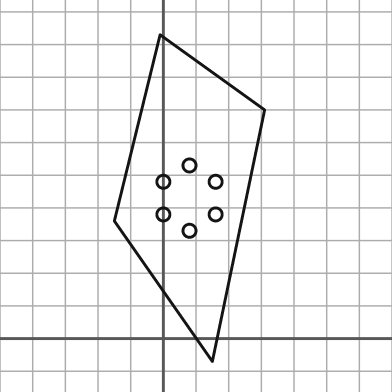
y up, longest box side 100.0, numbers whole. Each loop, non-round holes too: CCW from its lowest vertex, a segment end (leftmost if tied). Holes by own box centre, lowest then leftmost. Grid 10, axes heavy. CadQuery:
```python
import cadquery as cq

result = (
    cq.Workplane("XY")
    .moveTo(15.0, -7.0)
    .lineTo(31.0, 70.0)
    .lineTo(-1.0, 93.0)
    .lineTo(-15.0, 36.0)
    .close()
    .moveTo(8.0, 33.0)
    .circle(2.0)
    .moveTo(0.0, 38.0)
    .circle(2.0)
    .moveTo(16.0, 38.0)
    .circle(2.0)
    .moveTo(0.0, 48.0)
    .circle(2.0)
    .moveTo(16.0, 48.0)
    .circle(2.0)
    .moveTo(8.0, 53.0)
    .circle(2.0)
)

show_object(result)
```